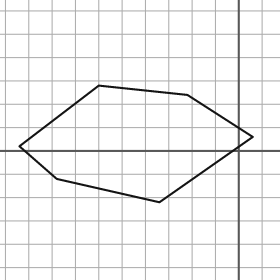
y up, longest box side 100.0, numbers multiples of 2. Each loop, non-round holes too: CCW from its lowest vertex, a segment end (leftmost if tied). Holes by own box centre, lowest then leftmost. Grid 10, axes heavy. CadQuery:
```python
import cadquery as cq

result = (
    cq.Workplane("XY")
    .moveTo(-34.0, -22.0)
    .lineTo(6.0, 6.0)
    .lineTo(-22.0, 24.0)
    .lineTo(-60.0, 28.0)
    .lineTo(-94.0, 2.0)
    .lineTo(-78.0, -12.0)
    .close()
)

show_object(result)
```